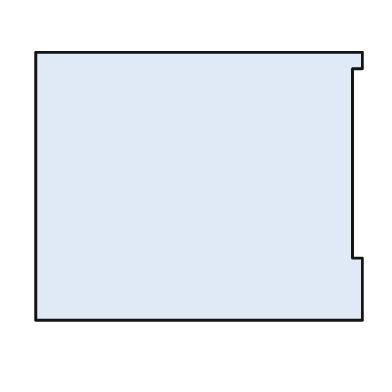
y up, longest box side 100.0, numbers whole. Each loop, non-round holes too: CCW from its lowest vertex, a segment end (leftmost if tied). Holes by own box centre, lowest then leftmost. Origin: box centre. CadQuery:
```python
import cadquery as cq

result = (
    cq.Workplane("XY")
    .moveTo(-50.0, -41.0)
    .lineTo(50.0, -41.0)
    .lineTo(50.0, -22.0)
    .lineTo(47.0, -22.0)
    .lineTo(47.0, 36.0)
    .lineTo(50.0, 36.0)
    .lineTo(50.0, 41.0)
    .lineTo(-50.0, 41.0)
    .close()
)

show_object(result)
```